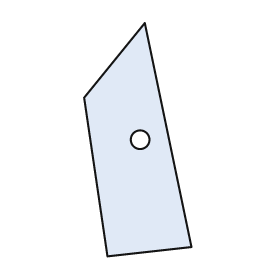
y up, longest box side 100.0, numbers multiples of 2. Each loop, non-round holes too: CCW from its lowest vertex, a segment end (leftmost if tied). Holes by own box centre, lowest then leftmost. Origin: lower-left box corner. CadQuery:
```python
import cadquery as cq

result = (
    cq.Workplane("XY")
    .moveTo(10.0, 0.0)
    .lineTo(46.0, 4.0)
    .lineTo(26.0, 100.0)
    .lineTo(0.0, 68.0)
    .close()
    .moveTo(24.0, 50.0)
    .circle(4.0)
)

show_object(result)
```